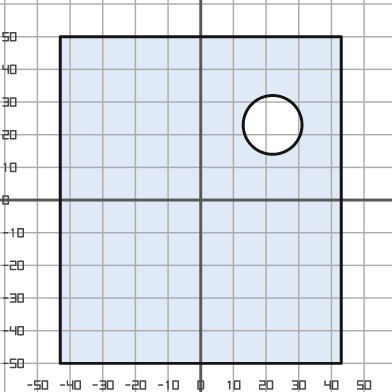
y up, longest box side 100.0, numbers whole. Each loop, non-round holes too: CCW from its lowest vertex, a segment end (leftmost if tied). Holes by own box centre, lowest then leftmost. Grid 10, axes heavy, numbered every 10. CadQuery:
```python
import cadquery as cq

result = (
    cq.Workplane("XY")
    .moveTo(-43.0, -50.0)
    .lineTo(43.0, -50.0)
    .lineTo(43.0, 50.0)
    .lineTo(-43.0, 50.0)
    .close()
    .moveTo(22.0, 23.0)
    .circle(9.0)
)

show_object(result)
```